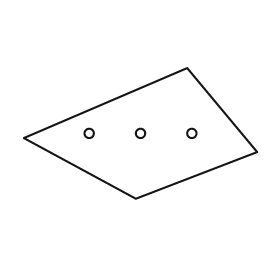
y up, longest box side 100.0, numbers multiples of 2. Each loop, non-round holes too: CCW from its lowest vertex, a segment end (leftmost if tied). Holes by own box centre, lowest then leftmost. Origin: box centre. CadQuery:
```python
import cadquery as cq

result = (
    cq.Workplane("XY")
    .moveTo(-2.0, -28.0)
    .lineTo(50.0, -8.0)
    .lineTo(20.0, 28.0)
    .lineTo(-50.0, -2.0)
    .close()
    .moveTo(-22.0, 0.0)
    .circle(2.0)
    .moveTo(0.0, 0.0)
    .circle(2.0)
    .moveTo(22.0, 0.0)
    .circle(2.0)
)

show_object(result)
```